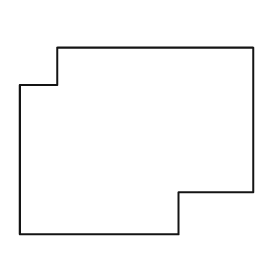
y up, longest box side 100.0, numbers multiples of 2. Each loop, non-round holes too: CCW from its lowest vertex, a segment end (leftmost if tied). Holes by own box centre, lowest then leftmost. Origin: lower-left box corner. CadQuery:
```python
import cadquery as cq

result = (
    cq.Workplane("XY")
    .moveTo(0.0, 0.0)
    .lineTo(68.0, 0.0)
    .lineTo(68.0, 18.0)
    .lineTo(100.0, 18.0)
    .lineTo(100.0, 80.0)
    .lineTo(16.0, 80.0)
    .lineTo(16.0, 64.0)
    .lineTo(0.0, 64.0)
    .close()
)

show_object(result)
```